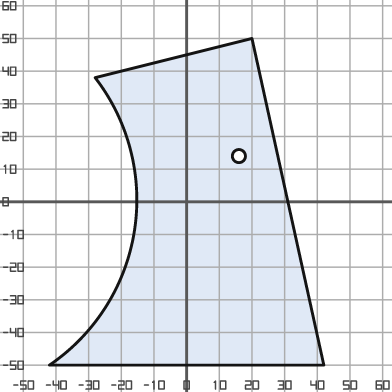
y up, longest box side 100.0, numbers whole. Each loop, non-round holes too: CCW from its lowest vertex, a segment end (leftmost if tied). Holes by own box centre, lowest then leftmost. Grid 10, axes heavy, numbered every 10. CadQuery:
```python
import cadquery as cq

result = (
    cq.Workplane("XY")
    .moveTo(-42.0, -50.0)
    .lineTo(42.0, -50.0)
    .lineTo(20.0, 50.0)
    .lineTo(-28.0, 38.0)
    .threePointArc((-16.0, -9.0), (-42.0, -50.0))
    .close()
    .moveTo(16.0, 14.0)
    .circle(2.0)
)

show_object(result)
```